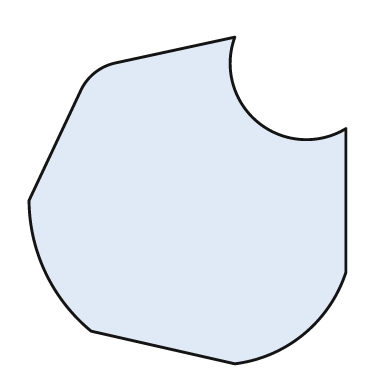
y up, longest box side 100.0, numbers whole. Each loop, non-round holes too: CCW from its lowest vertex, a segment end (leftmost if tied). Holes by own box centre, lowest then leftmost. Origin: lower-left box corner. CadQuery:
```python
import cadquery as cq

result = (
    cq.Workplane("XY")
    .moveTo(63.0, 0.0)
    .threePointArc((84.0, 9.0), (97.0, 28.0))
    .lineTo(97.0, 72.0)
    .threePointArc((70.0, 74.0), (63.0, 100.0))
    .lineTo(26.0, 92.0)
    .threePointArc((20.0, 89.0), (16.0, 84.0))
    .lineTo(0.0, 50.0)
    .threePointArc((5.0, 28.0), (19.0, 10.0))
    .close()
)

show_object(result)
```